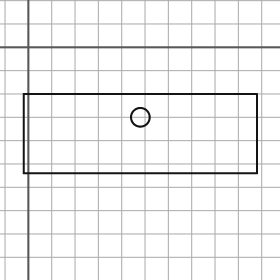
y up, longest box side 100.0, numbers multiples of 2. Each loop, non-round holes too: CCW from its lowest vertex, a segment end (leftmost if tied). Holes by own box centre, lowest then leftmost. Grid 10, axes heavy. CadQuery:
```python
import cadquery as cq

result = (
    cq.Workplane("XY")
    .moveTo(-2.0, -54.0)
    .lineTo(98.0, -54.0)
    .lineTo(98.0, -20.0)
    .lineTo(-2.0, -20.0)
    .close()
    .moveTo(48.0, -30.0)
    .circle(4.0)
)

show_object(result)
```